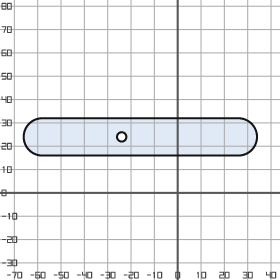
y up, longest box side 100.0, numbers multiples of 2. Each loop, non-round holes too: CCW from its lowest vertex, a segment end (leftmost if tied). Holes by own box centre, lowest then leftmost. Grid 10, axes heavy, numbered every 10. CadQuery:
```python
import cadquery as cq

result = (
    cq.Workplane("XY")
    .moveTo(-58.0, 16.0)
    .lineTo(26.0, 16.0)
    .threePointArc((34.0, 24.0), (26.0, 32.0))
    .lineTo(-58.0, 32.0)
    .threePointArc((-66.0, 24.0), (-58.0, 16.0))
    .close()
    .moveTo(-24.0, 24.0)
    .circle(2.0)
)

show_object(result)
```